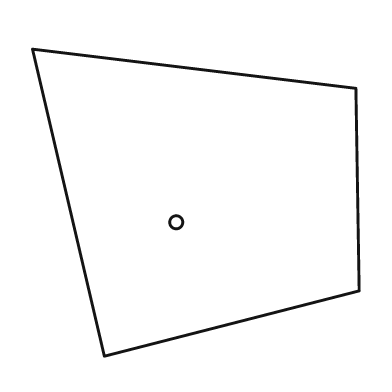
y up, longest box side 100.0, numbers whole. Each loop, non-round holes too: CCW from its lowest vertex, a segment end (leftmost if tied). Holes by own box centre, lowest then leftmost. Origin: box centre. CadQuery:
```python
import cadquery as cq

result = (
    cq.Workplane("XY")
    .moveTo(-28.0, -47.0)
    .lineTo(50.0, -27.0)
    .lineTo(49.0, 35.0)
    .lineTo(-50.0, 47.0)
    .close()
    .moveTo(-6.0, -6.0)
    .circle(2.0)
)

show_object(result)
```